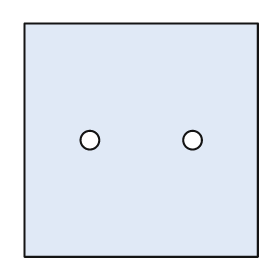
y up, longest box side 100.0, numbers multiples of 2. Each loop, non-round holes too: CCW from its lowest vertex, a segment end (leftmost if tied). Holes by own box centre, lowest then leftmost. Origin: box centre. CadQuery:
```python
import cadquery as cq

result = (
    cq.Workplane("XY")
    .moveTo(-50.0, -50.0)
    .lineTo(50.0, -50.0)
    .lineTo(50.0, 50.0)
    .lineTo(-50.0, 50.0)
    .close()
    .moveTo(-22.0, 0.0)
    .circle(4.0)
    .moveTo(22.0, 0.0)
    .circle(4.0)
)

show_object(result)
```